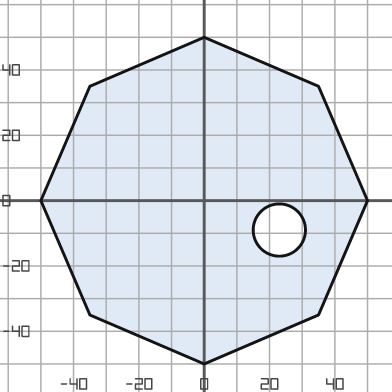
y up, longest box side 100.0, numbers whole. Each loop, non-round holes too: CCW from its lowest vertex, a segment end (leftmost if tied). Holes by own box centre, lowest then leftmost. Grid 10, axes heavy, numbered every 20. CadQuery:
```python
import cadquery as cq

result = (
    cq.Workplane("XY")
    .moveTo(0.0, -50.0)
    .lineTo(35.0, -35.0)
    .lineTo(50.0, 0.0)
    .lineTo(35.0, 35.0)
    .lineTo(0.0, 50.0)
    .lineTo(-35.0, 35.0)
    .lineTo(-50.0, 0.0)
    .lineTo(-35.0, -35.0)
    .close()
    .moveTo(23.0, -9.0)
    .circle(8.0)
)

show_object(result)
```